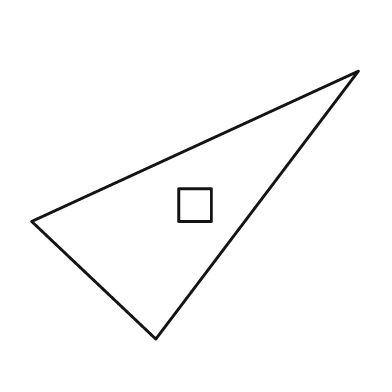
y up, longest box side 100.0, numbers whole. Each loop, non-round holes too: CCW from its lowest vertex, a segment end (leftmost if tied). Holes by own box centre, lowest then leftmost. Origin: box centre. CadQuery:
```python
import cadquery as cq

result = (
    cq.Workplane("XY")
    .moveTo(-12.0, -41.0)
    .lineTo(50.0, 41.0)
    .lineTo(-50.0, -5.0)
    .close()
    .moveTo(-5.0, -5.0)
    .lineTo(5.0, -5.0)
    .lineTo(5.0, 5.0)
    .lineTo(-5.0, 5.0)
    .close()
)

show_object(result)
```